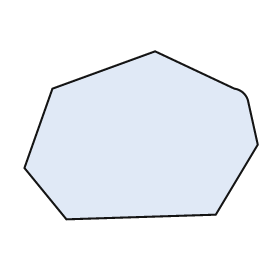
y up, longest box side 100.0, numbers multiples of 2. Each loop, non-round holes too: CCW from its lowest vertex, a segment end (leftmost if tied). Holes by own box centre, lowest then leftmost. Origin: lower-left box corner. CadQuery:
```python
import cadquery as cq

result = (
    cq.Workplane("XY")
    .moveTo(18.0, 0.0)
    .lineTo(82.0, 2.0)
    .lineTo(100.0, 32.0)
    .lineTo(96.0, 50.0)
    .threePointArc((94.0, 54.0), (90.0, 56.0))
    .lineTo(56.0, 72.0)
    .lineTo(12.0, 56.0)
    .lineTo(0.0, 22.0)
    .close()
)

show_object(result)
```